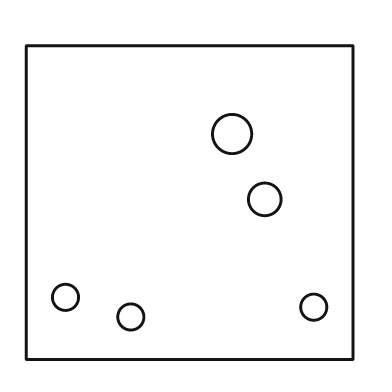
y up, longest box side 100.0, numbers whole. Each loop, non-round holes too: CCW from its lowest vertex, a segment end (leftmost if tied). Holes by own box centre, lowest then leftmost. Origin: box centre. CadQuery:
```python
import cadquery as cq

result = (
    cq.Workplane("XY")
    .moveTo(-50.0, -48.0)
    .lineTo(50.0, -48.0)
    .lineTo(50.0, 48.0)
    .lineTo(-50.0, 48.0)
    .close()
    .moveTo(-18.0, -35.0)
    .circle(4.0)
    .moveTo(38.0, -32.0)
    .circle(4.0)
    .moveTo(-38.0, -29.0)
    .circle(4.0)
    .moveTo(23.0, 1.0)
    .circle(5.0)
    .moveTo(13.0, 21.0)
    .circle(6.0)
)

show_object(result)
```